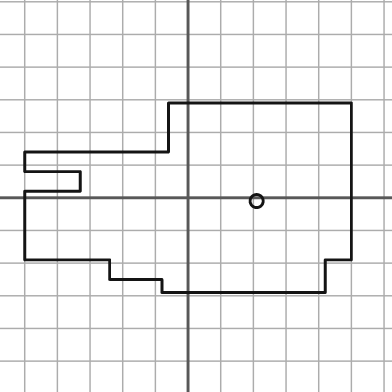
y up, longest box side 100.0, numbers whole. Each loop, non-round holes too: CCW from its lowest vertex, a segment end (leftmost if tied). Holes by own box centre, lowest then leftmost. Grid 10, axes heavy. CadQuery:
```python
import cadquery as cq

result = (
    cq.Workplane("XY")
    .moveTo(-8.0, -29.0)
    .lineTo(42.0, -29.0)
    .lineTo(42.0, -19.0)
    .lineTo(50.0, -19.0)
    .lineTo(50.0, 29.0)
    .lineTo(-6.0, 29.0)
    .lineTo(-6.0, 14.0)
    .lineTo(-50.0, 14.0)
    .lineTo(-50.0, 8.0)
    .lineTo(-33.0, 8.0)
    .lineTo(-33.0, 2.0)
    .lineTo(-50.0, 2.0)
    .lineTo(-50.0, -19.0)
    .lineTo(-24.0, -19.0)
    .lineTo(-24.0, -25.0)
    .lineTo(-8.0, -25.0)
    .close()
    .moveTo(21.0, -1.0)
    .circle(2.0)
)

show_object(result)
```